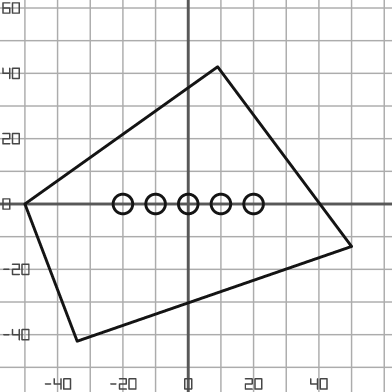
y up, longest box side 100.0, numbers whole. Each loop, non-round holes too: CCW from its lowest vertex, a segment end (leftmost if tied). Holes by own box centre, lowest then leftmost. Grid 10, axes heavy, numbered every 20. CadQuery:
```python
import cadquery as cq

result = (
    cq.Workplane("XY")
    .moveTo(-34.0, -42.0)
    .lineTo(50.0, -13.0)
    .lineTo(9.0, 42.0)
    .lineTo(-50.0, 0.0)
    .close()
    .moveTo(-20.0, 0.0)
    .circle(3.0)
    .moveTo(-10.0, 0.0)
    .circle(3.0)
    .moveTo(0.0, 0.0)
    .circle(3.0)
    .moveTo(10.0, 0.0)
    .circle(3.0)
    .moveTo(20.0, 0.0)
    .circle(3.0)
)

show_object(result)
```